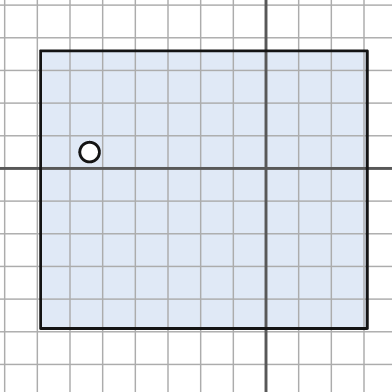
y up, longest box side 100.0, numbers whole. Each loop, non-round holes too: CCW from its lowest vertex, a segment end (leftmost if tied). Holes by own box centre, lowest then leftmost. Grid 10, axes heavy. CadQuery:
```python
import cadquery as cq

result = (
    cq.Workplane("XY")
    .moveTo(-69.0, -49.0)
    .lineTo(31.0, -49.0)
    .lineTo(31.0, 36.0)
    .lineTo(-69.0, 36.0)
    .close()
    .moveTo(-54.0, 5.0)
    .circle(3.0)
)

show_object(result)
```